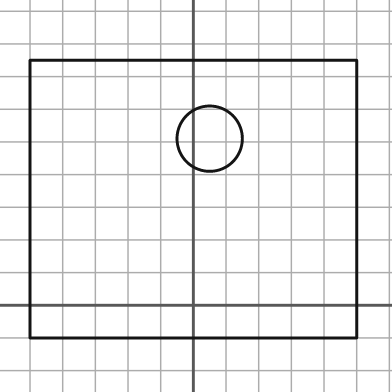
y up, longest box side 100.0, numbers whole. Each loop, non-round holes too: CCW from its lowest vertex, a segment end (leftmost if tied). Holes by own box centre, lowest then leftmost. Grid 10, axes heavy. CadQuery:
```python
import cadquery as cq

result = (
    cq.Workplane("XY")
    .moveTo(-50.0, -10.0)
    .lineTo(50.0, -10.0)
    .lineTo(50.0, 75.0)
    .lineTo(-50.0, 75.0)
    .close()
    .moveTo(5.0, 51.0)
    .circle(10.0)
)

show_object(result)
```